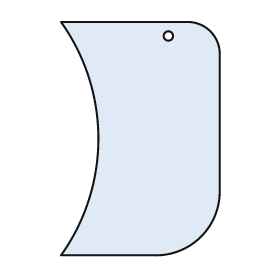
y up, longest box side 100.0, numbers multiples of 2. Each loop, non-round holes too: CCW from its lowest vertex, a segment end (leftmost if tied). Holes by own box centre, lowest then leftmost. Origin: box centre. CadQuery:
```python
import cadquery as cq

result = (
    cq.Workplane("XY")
    .moveTo(-34.0, -50.0)
    .lineTo(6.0, -50.0)
    .threePointArc((26.0, -42.0), (34.0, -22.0))
    .lineTo(34.0, 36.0)
    .threePointArc((30.0, 46.0), (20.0, 50.0))
    .lineTo(-34.0, 50.0)
    .threePointArc((-18.0, 0.0), (-34.0, -50.0))
    .close()
    .moveTo(12.0, 44.0)
    .circle(2.0)
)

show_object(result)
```